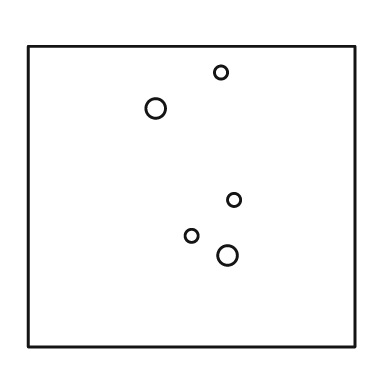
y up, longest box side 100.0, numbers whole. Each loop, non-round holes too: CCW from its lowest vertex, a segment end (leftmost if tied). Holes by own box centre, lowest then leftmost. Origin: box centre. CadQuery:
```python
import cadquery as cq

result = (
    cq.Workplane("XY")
    .moveTo(-50.0, -46.0)
    .lineTo(50.0, -46.0)
    .lineTo(50.0, 46.0)
    .lineTo(-50.0, 46.0)
    .close()
    .moveTo(11.0, -18.0)
    .circle(3.0)
    .moveTo(0.0, -12.0)
    .circle(2.0)
    .moveTo(13.0, -1.0)
    .circle(2.0)
    .moveTo(-11.0, 27.0)
    .circle(3.0)
    .moveTo(9.0, 38.0)
    .circle(2.0)
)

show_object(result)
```